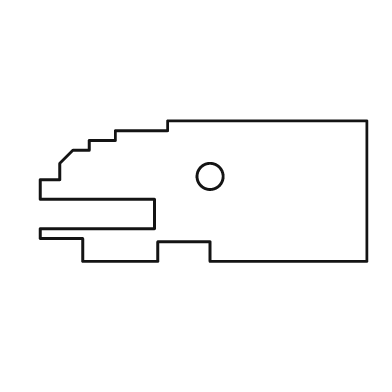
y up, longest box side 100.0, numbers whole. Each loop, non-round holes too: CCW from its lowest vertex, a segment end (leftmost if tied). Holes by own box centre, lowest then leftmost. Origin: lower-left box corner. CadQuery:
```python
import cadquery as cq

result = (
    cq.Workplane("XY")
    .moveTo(13.0, 0.0)
    .lineTo(36.0, 0.0)
    .lineTo(36.0, 6.0)
    .lineTo(52.0, 6.0)
    .lineTo(52.0, 0.0)
    .lineTo(100.0, 0.0)
    .lineTo(100.0, 43.0)
    .lineTo(39.0, 43.0)
    .lineTo(39.0, 40.0)
    .lineTo(23.0, 40.0)
    .lineTo(23.0, 37.0)
    .lineTo(15.0, 37.0)
    .lineTo(15.0, 34.0)
    .lineTo(10.0, 34.0)
    .lineTo(6.0, 30.0)
    .lineTo(6.0, 25.0)
    .lineTo(0.0, 25.0)
    .lineTo(0.0, 19.0)
    .lineTo(35.0, 19.0)
    .lineTo(35.0, 10.0)
    .lineTo(0.0, 10.0)
    .lineTo(0.0, 7.0)
    .lineTo(13.0, 7.0)
    .close()
    .moveTo(52.0, 26.0)
    .circle(4.0)
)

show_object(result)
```